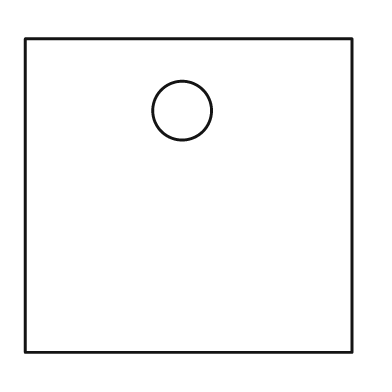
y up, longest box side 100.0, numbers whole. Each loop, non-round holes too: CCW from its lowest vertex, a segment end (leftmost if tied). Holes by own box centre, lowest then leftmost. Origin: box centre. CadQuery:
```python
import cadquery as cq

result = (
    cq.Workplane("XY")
    .moveTo(-50.0, -48.0)
    .lineTo(50.0, -48.0)
    .lineTo(50.0, 48.0)
    .lineTo(-50.0, 48.0)
    .close()
    .moveTo(-2.0, 26.0)
    .circle(9.0)
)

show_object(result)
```